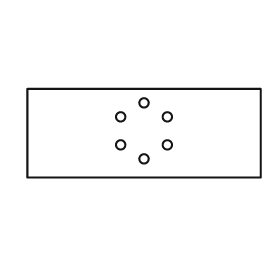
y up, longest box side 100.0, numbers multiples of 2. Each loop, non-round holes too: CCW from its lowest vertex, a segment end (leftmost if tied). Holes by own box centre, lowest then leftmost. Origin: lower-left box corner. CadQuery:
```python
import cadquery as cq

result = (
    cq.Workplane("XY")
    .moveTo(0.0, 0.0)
    .lineTo(100.0, 0.0)
    .lineTo(100.0, 38.0)
    .lineTo(0.0, 38.0)
    .close()
    .moveTo(50.0, 8.0)
    .circle(2.0)
    .moveTo(40.0, 14.0)
    .circle(2.0)
    .moveTo(60.0, 14.0)
    .circle(2.0)
    .moveTo(40.0, 26.0)
    .circle(2.0)
    .moveTo(60.0, 26.0)
    .circle(2.0)
    .moveTo(50.0, 32.0)
    .circle(2.0)
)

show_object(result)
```